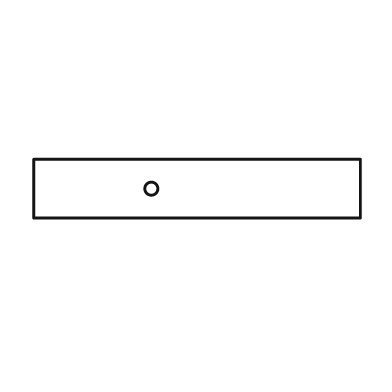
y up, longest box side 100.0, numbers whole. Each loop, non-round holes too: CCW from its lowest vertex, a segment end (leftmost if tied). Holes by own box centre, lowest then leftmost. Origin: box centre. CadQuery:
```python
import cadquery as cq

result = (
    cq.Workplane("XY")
    .moveTo(-50.0, -9.0)
    .lineTo(50.0, -9.0)
    .lineTo(50.0, 9.0)
    .lineTo(-50.0, 9.0)
    .close()
    .moveTo(-14.0, 0.0)
    .circle(2.0)
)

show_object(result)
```